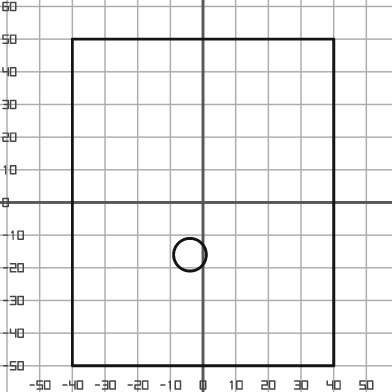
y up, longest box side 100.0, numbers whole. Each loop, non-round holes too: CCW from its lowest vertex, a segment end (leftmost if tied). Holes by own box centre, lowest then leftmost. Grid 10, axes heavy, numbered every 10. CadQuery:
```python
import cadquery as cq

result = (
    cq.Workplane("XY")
    .moveTo(-40.0, -50.0)
    .lineTo(40.0, -50.0)
    .lineTo(40.0, 50.0)
    .lineTo(-40.0, 50.0)
    .close()
    .moveTo(-4.0, -16.0)
    .circle(5.0)
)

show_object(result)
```